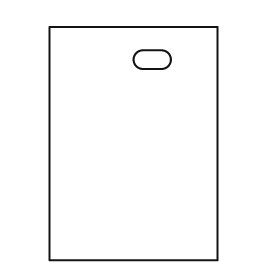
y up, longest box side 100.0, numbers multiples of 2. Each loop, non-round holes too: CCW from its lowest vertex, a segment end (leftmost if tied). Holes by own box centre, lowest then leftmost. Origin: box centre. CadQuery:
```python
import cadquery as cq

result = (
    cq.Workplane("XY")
    .moveTo(-36.0, -50.0)
    .lineTo(36.0, -50.0)
    .lineTo(36.0, 50.0)
    .lineTo(-36.0, 50.0)
    .close()
    .moveTo(4.0, 32.0)
    .lineTo(12.0, 32.0)
    .threePointArc((16.0, 36.0), (12.0, 40.0))
    .lineTo(4.0, 40.0)
    .threePointArc((0.0, 36.0), (4.0, 32.0))
    .close()
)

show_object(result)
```